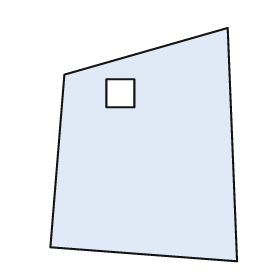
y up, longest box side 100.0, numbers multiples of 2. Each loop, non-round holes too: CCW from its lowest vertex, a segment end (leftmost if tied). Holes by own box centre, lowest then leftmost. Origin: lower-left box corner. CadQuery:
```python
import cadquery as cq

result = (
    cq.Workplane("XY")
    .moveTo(80.0, 0.0)
    .lineTo(76.0, 100.0)
    .lineTo(6.0, 80.0)
    .lineTo(0.0, 6.0)
    .close()
    .moveTo(24.0, 66.0)
    .lineTo(36.0, 66.0)
    .lineTo(36.0, 78.0)
    .lineTo(24.0, 78.0)
    .close()
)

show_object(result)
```